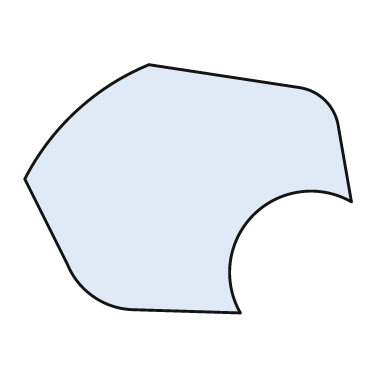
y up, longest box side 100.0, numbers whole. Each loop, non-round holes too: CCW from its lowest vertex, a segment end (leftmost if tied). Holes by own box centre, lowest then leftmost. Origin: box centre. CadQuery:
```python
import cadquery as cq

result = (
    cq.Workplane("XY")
    .moveTo(16.0, -38.0)
    .threePointArc((20.0, -8.0), (50.0, -4.0))
    .lineTo(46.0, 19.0)
    .threePointArc((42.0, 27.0), (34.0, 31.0))
    .lineTo(-12.0, 38.0)
    .threePointArc((-34.0, 24.0), (-50.0, 3.0))
    .lineTo(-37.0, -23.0)
    .threePointArc((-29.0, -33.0), (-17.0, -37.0))
    .close()
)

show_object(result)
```